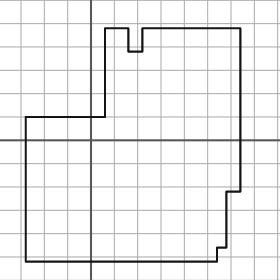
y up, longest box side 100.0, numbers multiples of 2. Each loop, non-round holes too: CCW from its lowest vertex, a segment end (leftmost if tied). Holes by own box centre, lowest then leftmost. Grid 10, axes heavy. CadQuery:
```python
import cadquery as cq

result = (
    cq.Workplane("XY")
    .moveTo(-28.0, -52.0)
    .lineTo(54.0, -52.0)
    .lineTo(54.0, -46.0)
    .lineTo(58.0, -46.0)
    .lineTo(58.0, -22.0)
    .lineTo(64.0, -22.0)
    .lineTo(64.0, 48.0)
    .lineTo(22.0, 48.0)
    .lineTo(22.0, 38.0)
    .lineTo(16.0, 38.0)
    .lineTo(16.0, 48.0)
    .lineTo(6.0, 48.0)
    .lineTo(6.0, 10.0)
    .lineTo(-28.0, 10.0)
    .close()
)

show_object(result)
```